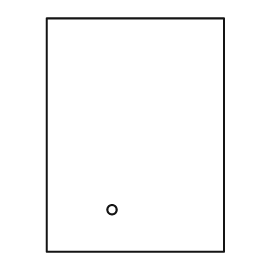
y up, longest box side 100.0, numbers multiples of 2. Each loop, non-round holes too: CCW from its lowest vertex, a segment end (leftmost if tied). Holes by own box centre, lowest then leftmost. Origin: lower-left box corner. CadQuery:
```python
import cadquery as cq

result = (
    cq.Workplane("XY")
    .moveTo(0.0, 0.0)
    .lineTo(76.0, 0.0)
    .lineTo(76.0, 100.0)
    .lineTo(0.0, 100.0)
    .close()
    .moveTo(28.0, 18.0)
    .circle(2.0)
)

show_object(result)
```